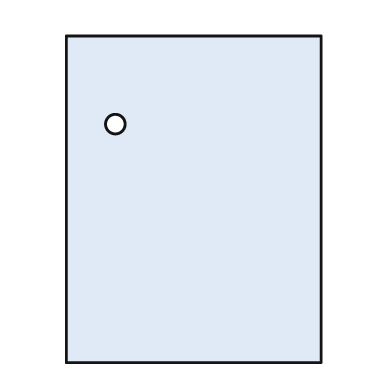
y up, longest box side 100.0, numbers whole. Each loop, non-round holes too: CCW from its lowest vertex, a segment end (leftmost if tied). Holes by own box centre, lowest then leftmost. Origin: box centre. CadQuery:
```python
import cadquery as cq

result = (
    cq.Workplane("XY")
    .moveTo(-39.0, -50.0)
    .lineTo(39.0, -50.0)
    .lineTo(39.0, 50.0)
    .lineTo(-39.0, 50.0)
    .close()
    .moveTo(-24.0, 23.0)
    .circle(3.0)
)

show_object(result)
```